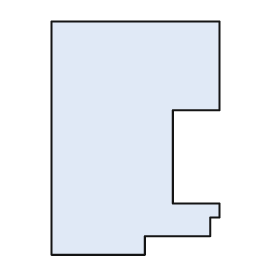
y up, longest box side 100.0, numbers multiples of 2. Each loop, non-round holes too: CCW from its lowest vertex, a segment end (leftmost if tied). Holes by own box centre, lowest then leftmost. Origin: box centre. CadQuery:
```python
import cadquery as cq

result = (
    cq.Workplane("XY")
    .moveTo(-36.0, -50.0)
    .lineTo(4.0, -50.0)
    .lineTo(4.0, -42.0)
    .lineTo(32.0, -42.0)
    .lineTo(32.0, -34.0)
    .lineTo(36.0, -34.0)
    .lineTo(36.0, -28.0)
    .lineTo(16.0, -28.0)
    .lineTo(16.0, 12.0)
    .lineTo(36.0, 12.0)
    .lineTo(36.0, 50.0)
    .lineTo(-36.0, 50.0)
    .close()
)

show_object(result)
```